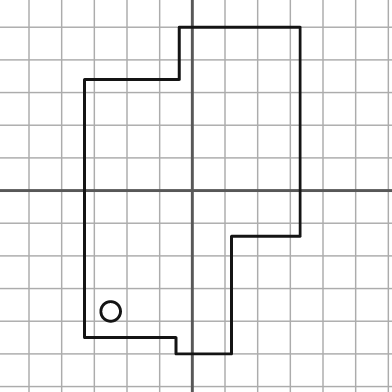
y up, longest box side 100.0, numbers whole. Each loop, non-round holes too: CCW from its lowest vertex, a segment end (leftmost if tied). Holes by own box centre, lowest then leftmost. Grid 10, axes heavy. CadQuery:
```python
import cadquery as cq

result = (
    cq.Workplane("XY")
    .moveTo(-5.0, -50.0)
    .lineTo(12.0, -50.0)
    .lineTo(12.0, -14.0)
    .lineTo(33.0, -14.0)
    .lineTo(33.0, 50.0)
    .lineTo(-4.0, 50.0)
    .lineTo(-4.0, 34.0)
    .lineTo(-33.0, 34.0)
    .lineTo(-33.0, -45.0)
    .lineTo(-5.0, -45.0)
    .close()
    .moveTo(-25.0, -37.0)
    .circle(3.0)
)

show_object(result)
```